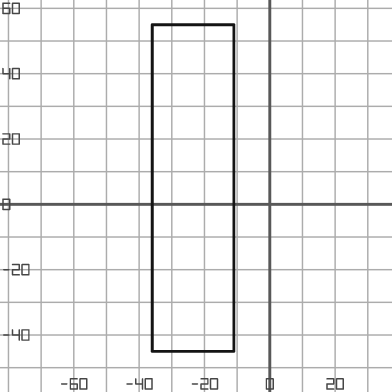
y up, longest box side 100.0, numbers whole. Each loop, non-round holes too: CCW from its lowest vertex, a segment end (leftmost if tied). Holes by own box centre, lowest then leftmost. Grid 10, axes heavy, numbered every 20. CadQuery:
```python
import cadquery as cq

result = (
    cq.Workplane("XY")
    .moveTo(-36.0, -45.0)
    .lineTo(-11.0, -45.0)
    .lineTo(-11.0, 55.0)
    .lineTo(-36.0, 55.0)
    .close()
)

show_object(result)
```